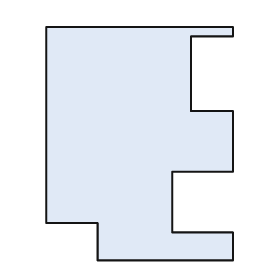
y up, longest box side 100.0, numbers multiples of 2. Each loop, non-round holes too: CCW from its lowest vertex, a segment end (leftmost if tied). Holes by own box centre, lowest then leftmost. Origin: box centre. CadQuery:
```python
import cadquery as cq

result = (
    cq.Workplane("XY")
    .moveTo(-18.0, -50.0)
    .lineTo(40.0, -50.0)
    .lineTo(40.0, -38.0)
    .lineTo(14.0, -38.0)
    .lineTo(14.0, -12.0)
    .lineTo(40.0, -12.0)
    .lineTo(40.0, 14.0)
    .lineTo(22.0, 14.0)
    .lineTo(22.0, 46.0)
    .lineTo(40.0, 46.0)
    .lineTo(40.0, 50.0)
    .lineTo(-40.0, 50.0)
    .lineTo(-40.0, -34.0)
    .lineTo(-18.0, -34.0)
    .close()
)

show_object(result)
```